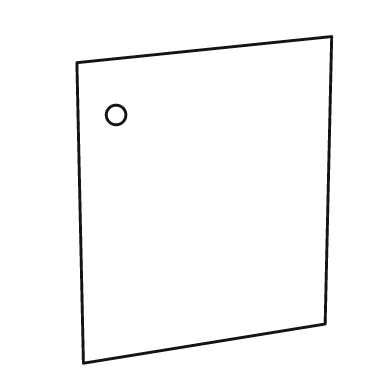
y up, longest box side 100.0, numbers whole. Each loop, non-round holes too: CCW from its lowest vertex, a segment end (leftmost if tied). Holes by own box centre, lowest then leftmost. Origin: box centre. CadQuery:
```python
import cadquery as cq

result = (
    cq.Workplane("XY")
    .moveTo(-37.0, -50.0)
    .lineTo(37.0, -38.0)
    .lineTo(39.0, 50.0)
    .lineTo(-39.0, 42.0)
    .close()
    .moveTo(-27.0, 26.0)
    .circle(3.0)
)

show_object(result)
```